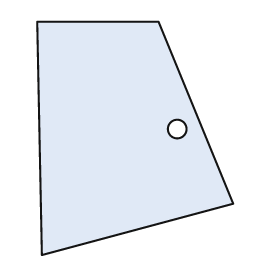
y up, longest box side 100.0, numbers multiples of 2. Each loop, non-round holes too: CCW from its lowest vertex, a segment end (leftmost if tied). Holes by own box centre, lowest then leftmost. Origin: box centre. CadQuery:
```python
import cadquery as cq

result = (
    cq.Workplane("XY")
    .moveTo(-40.0, -50.0)
    .lineTo(42.0, -28.0)
    .lineTo(10.0, 50.0)
    .lineTo(-42.0, 50.0)
    .close()
    .moveTo(18.0, 4.0)
    .circle(4.0)
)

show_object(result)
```